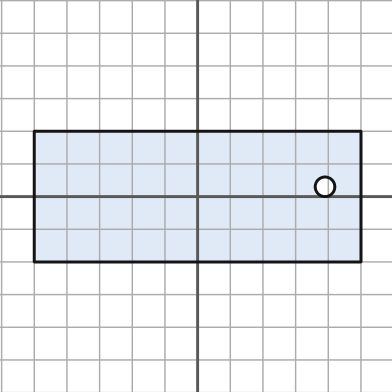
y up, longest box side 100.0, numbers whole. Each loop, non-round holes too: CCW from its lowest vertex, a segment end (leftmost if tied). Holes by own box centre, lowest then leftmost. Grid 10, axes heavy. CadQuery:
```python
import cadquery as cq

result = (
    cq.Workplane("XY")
    .moveTo(-50.0, -20.0)
    .lineTo(50.0, -20.0)
    .lineTo(50.0, 20.0)
    .lineTo(-50.0, 20.0)
    .close()
    .moveTo(39.0, 3.0)
    .circle(3.0)
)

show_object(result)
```